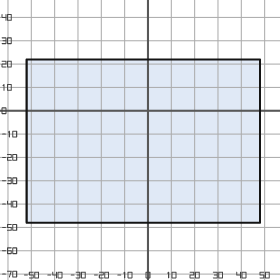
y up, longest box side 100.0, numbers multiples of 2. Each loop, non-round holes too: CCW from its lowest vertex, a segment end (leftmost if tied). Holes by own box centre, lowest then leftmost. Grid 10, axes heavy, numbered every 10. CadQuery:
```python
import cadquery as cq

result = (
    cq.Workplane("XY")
    .moveTo(-52.0, -48.0)
    .lineTo(48.0, -48.0)
    .lineTo(48.0, 22.0)
    .lineTo(-52.0, 22.0)
    .close()
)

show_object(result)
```